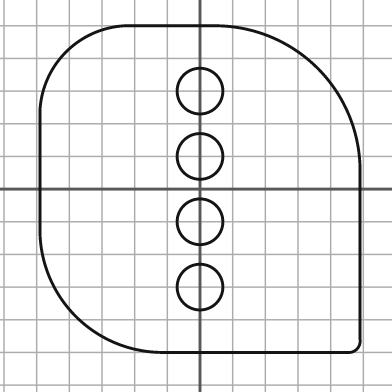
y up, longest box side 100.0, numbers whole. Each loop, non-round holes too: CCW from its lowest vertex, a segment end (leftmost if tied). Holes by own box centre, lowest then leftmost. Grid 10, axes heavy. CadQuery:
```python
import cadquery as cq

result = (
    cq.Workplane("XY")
    .moveTo(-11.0, -50.0)
    .lineTo(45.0, -50.0)
    .threePointArc((48.0, -49.0), (49.0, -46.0))
    .lineTo(49.0, 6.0)
    .threePointArc((36.0, 37.0), (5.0, 50.0))
    .lineTo(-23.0, 50.0)
    .threePointArc((-41.0, 42.0), (-49.0, 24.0))
    .lineTo(-49.0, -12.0)
    .threePointArc((-38.0, -39.0), (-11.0, -50.0))
    .close()
    .moveTo(0.0, -30.0)
    .circle(7.0)
    .moveTo(0.0, -10.0)
    .circle(7.0)
    .moveTo(0.0, 10.0)
    .circle(7.0)
    .moveTo(0.0, 30.0)
    .circle(7.0)
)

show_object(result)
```